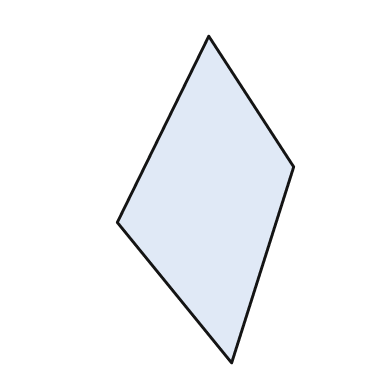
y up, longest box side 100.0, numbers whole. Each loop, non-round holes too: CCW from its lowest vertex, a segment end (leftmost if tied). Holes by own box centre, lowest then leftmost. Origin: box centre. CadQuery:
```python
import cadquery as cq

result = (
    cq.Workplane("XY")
    .moveTo(8.0, -50.0)
    .lineTo(27.0, 10.0)
    .lineTo(1.0, 50.0)
    .lineTo(-27.0, -7.0)
    .close()
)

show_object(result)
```